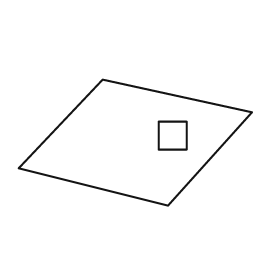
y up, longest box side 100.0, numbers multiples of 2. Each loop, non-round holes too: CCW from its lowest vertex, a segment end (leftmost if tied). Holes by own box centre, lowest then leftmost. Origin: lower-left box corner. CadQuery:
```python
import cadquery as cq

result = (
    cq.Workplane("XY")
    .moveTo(64.0, 0.0)
    .lineTo(100.0, 40.0)
    .lineTo(36.0, 54.0)
    .lineTo(0.0, 16.0)
    .close()
    .moveTo(60.0, 24.0)
    .lineTo(72.0, 24.0)
    .lineTo(72.0, 36.0)
    .lineTo(60.0, 36.0)
    .close()
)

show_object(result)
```